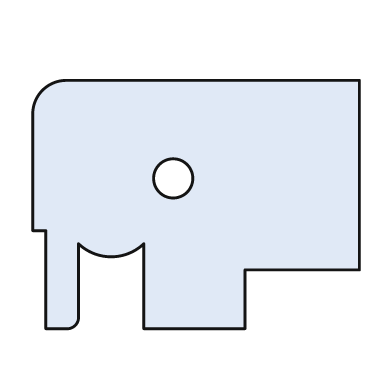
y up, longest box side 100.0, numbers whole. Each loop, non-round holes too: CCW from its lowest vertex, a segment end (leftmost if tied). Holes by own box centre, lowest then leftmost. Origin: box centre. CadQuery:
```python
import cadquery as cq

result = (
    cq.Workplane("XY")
    .moveTo(-46.0, -38.0)
    .lineTo(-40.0, -38.0)
    .threePointArc((-37.0, -37.0), (-36.0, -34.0))
    .lineTo(-36.0, -12.0)
    .threePointArc((-26.0, -16.0), (-16.0, -12.0))
    .lineTo(-16.0, -38.0)
    .lineTo(15.0, -38.0)
    .lineTo(15.0, -20.0)
    .lineTo(50.0, -20.0)
    .lineTo(50.0, 38.0)
    .lineTo(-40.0, 38.0)
    .threePointArc((-47.0, 35.0), (-50.0, 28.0))
    .lineTo(-50.0, -8.0)
    .lineTo(-46.0, -8.0)
    .close()
    .moveTo(-7.0, 8.0)
    .circle(6.0)
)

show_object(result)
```